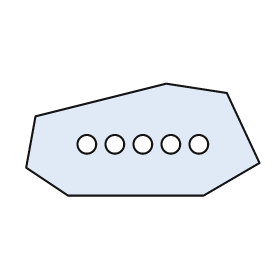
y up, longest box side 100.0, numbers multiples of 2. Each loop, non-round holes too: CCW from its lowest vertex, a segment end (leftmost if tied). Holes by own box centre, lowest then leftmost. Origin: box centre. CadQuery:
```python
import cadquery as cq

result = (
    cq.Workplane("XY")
    .moveTo(-32.0, -24.0)
    .lineTo(26.0, -24.0)
    .lineTo(50.0, -10.0)
    .lineTo(36.0, 20.0)
    .lineTo(10.0, 24.0)
    .lineTo(-46.0, 10.0)
    .lineTo(-50.0, -12.0)
    .close()
    .moveTo(-24.0, -2.0)
    .circle(4.0)
    .moveTo(-12.0, -2.0)
    .circle(4.0)
    .moveTo(0.0, -2.0)
    .circle(4.0)
    .moveTo(12.0, -2.0)
    .circle(4.0)
    .moveTo(24.0, -2.0)
    .circle(4.0)
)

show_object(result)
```